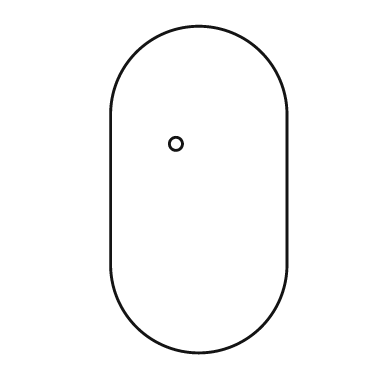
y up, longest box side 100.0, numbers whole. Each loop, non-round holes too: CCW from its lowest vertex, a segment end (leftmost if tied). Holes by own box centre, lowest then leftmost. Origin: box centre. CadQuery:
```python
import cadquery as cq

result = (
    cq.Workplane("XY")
    .moveTo(-27.0, -23.0)
    .threePointArc((0.0, -50.0), (27.0, -23.0))
    .lineTo(27.0, 23.0)
    .threePointArc((0.0, 50.0), (-27.0, 23.0))
    .close()
    .moveTo(-7.0, 14.0)
    .circle(2.0)
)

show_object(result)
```